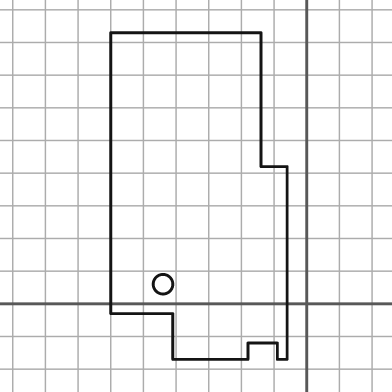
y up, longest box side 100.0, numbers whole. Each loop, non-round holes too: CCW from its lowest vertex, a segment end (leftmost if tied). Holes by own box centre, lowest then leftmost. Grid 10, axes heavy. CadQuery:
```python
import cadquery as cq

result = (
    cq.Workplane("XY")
    .moveTo(-41.0, -17.0)
    .lineTo(-18.0, -17.0)
    .lineTo(-18.0, -12.0)
    .lineTo(-9.0, -12.0)
    .lineTo(-9.0, -17.0)
    .lineTo(-6.0, -17.0)
    .lineTo(-6.0, 42.0)
    .lineTo(-14.0, 42.0)
    .lineTo(-14.0, 83.0)
    .lineTo(-60.0, 83.0)
    .lineTo(-60.0, -3.0)
    .lineTo(-41.0, -3.0)
    .close()
    .moveTo(-44.0, 6.0)
    .circle(3.0)
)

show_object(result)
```